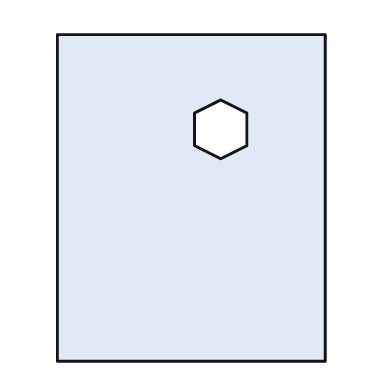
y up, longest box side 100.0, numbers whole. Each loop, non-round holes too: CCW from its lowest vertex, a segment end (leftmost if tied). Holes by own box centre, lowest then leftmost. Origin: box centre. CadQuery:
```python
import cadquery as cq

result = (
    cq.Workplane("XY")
    .moveTo(-41.0, -50.0)
    .lineTo(41.0, -50.0)
    .lineTo(41.0, 50.0)
    .lineTo(-41.0, 50.0)
    .close()
    .moveTo(9.0, 12.0)
    .lineTo(17.0, 16.0)
    .lineTo(17.0, 26.0)
    .lineTo(9.0, 30.0)
    .lineTo(1.0, 26.0)
    .lineTo(1.0, 16.0)
    .close()
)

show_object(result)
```